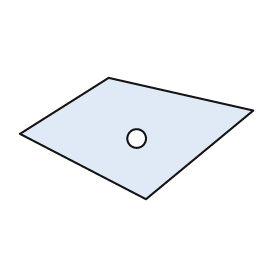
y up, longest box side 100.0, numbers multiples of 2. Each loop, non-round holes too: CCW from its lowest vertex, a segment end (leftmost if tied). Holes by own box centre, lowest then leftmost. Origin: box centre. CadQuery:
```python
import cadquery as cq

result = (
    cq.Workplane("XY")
    .moveTo(4.0, -26.0)
    .lineTo(50.0, 12.0)
    .lineTo(-12.0, 26.0)
    .lineTo(-50.0, 2.0)
    .close()
    .moveTo(0.0, 0.0)
    .circle(4.0)
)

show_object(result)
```